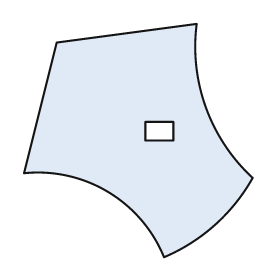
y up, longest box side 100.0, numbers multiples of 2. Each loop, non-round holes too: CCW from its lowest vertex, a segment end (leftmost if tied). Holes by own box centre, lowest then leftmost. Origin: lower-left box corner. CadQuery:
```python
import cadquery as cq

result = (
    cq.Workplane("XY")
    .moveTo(60.0, 0.0)
    .threePointArc((82.0, 14.0), (98.0, 34.0))
    .threePointArc((78.0, 64.0), (74.0, 100.0))
    .lineTo(14.0, 92.0)
    .lineTo(0.0, 36.0)
    .threePointArc((36.0, 28.0), (60.0, 0.0))
    .close()
    .moveTo(52.0, 50.0)
    .lineTo(64.0, 50.0)
    .lineTo(64.0, 58.0)
    .lineTo(52.0, 58.0)
    .close()
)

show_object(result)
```